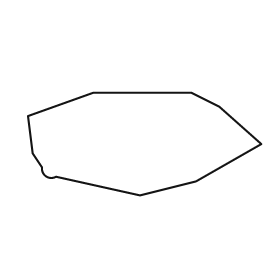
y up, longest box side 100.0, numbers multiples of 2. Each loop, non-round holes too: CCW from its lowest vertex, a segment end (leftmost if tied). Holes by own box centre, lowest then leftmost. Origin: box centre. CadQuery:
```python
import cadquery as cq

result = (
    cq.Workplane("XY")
    .moveTo(-2.0, -22.0)
    .lineTo(22.0, -16.0)
    .lineTo(50.0, 0.0)
    .lineTo(32.0, 16.0)
    .lineTo(20.0, 22.0)
    .lineTo(-22.0, 22.0)
    .lineTo(-50.0, 12.0)
    .lineTo(-48.0, -4.0)
    .lineTo(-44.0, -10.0)
    .threePointArc((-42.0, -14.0), (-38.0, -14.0))
    .close()
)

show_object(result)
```